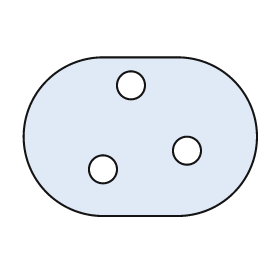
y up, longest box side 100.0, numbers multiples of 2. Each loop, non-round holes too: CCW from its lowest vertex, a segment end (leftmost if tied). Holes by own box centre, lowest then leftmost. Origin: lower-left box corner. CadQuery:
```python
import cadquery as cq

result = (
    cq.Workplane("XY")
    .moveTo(34.0, 0.0)
    .lineTo(66.0, 0.0)
    .threePointArc((100.0, 34.0), (66.0, 68.0))
    .lineTo(34.0, 68.0)
    .threePointArc((0.0, 34.0), (34.0, 0.0))
    .close()
    .moveTo(34.0, 20.0)
    .circle(6.0)
    .moveTo(70.0, 28.0)
    .circle(6.0)
    .moveTo(46.0, 56.0)
    .circle(6.0)
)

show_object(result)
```